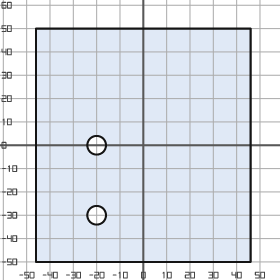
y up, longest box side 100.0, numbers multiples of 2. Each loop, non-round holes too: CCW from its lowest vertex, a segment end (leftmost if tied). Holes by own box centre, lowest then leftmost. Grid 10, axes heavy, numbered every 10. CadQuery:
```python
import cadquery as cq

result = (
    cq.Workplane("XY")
    .moveTo(-46.0, -50.0)
    .lineTo(46.0, -50.0)
    .lineTo(46.0, 50.0)
    .lineTo(-46.0, 50.0)
    .close()
    .moveTo(-20.0, -30.0)
    .circle(4.0)
    .moveTo(-20.0, 0.0)
    .circle(4.0)
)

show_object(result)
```